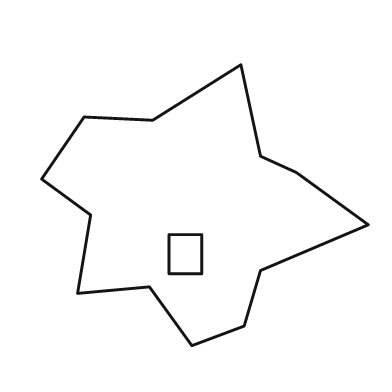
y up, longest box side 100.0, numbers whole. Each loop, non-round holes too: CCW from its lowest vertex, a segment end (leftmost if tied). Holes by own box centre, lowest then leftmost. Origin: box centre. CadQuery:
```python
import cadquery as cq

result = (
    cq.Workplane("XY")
    .moveTo(-4.0, -43.0)
    .lineTo(12.0, -37.0)
    .lineTo(17.0, -20.0)
    .lineTo(50.0, -6.0)
    .lineTo(28.0, 10.0)
    .lineTo(17.0, 15.0)
    .lineTo(11.0, 43.0)
    .lineTo(-16.0, 26.0)
    .lineTo(-37.0, 27.0)
    .lineTo(-50.0, 8.0)
    .lineTo(-35.0, -3.0)
    .lineTo(-39.0, -27.0)
    .lineTo(-17.0, -25.0)
    .close()
    .moveTo(-11.0, -21.0)
    .lineTo(-1.0, -21.0)
    .lineTo(-1.0, -9.0)
    .lineTo(-11.0, -9.0)
    .close()
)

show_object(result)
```